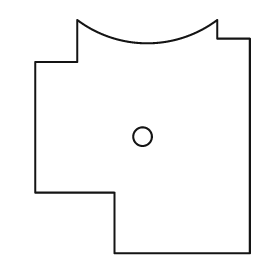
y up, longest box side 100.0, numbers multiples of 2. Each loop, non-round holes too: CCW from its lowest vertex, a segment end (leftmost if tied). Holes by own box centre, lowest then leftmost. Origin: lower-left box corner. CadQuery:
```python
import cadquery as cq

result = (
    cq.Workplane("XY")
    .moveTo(34.0, 0.0)
    .lineTo(92.0, 0.0)
    .lineTo(92.0, 92.0)
    .lineTo(78.0, 92.0)
    .lineTo(78.0, 100.0)
    .threePointArc((48.0, 90.0), (18.0, 100.0))
    .lineTo(18.0, 82.0)
    .lineTo(0.0, 82.0)
    .lineTo(0.0, 26.0)
    .lineTo(34.0, 26.0)
    .close()
    .moveTo(46.0, 50.0)
    .circle(4.0)
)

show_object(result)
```